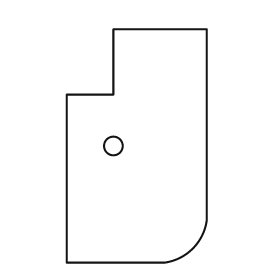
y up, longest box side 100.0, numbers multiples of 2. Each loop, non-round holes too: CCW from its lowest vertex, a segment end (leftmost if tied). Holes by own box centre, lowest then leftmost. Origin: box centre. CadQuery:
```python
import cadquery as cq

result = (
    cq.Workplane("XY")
    .moveTo(-30.0, -50.0)
    .lineTo(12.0, -50.0)
    .threePointArc((24.0, -44.0), (30.0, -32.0))
    .lineTo(30.0, 50.0)
    .lineTo(-10.0, 50.0)
    .lineTo(-10.0, 22.0)
    .lineTo(-30.0, 22.0)
    .close()
    .moveTo(-10.0, 0.0)
    .circle(4.0)
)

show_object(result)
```